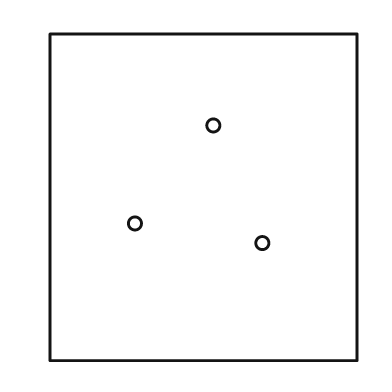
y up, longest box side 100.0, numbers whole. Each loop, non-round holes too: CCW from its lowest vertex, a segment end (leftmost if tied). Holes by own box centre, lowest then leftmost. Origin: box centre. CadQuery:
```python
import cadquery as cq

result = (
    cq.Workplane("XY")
    .moveTo(-47.0, -50.0)
    .lineTo(47.0, -50.0)
    .lineTo(47.0, 50.0)
    .lineTo(-47.0, 50.0)
    .close()
    .moveTo(18.0, -14.0)
    .circle(2.0)
    .moveTo(-21.0, -8.0)
    .circle(2.0)
    .moveTo(3.0, 22.0)
    .circle(2.0)
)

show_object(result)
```